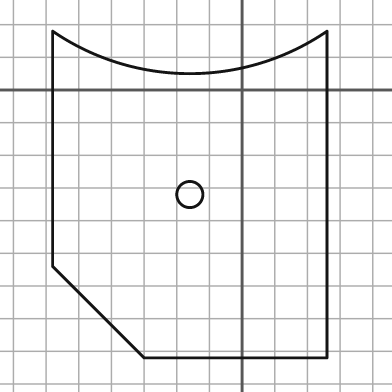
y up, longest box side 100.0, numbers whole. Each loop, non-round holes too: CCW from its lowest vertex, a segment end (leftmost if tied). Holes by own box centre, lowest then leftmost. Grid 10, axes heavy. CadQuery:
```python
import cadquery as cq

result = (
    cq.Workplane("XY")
    .moveTo(-30.0, -82.0)
    .lineTo(26.0, -82.0)
    .lineTo(26.0, 18.0)
    .threePointArc((-16.0, 5.0), (-58.0, 18.0))
    .lineTo(-58.0, -54.0)
    .close()
    .moveTo(-16.0, -32.0)
    .circle(4.0)
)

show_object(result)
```